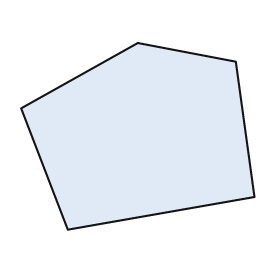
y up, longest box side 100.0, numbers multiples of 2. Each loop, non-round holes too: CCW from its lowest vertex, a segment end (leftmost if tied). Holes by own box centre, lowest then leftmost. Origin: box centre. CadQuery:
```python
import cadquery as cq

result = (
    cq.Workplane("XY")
    .moveTo(-30.0, -40.0)
    .lineTo(50.0, -26.0)
    .lineTo(42.0, 32.0)
    .lineTo(0.0, 40.0)
    .lineTo(-50.0, 12.0)
    .close()
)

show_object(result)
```